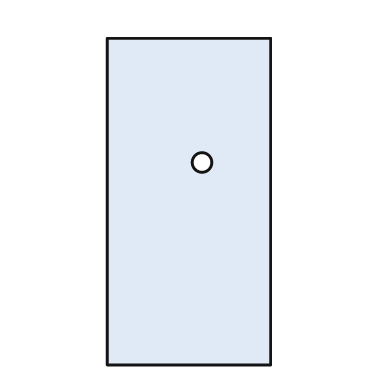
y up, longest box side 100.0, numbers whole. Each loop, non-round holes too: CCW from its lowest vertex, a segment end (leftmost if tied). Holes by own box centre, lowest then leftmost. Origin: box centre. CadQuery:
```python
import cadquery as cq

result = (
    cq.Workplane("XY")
    .moveTo(-25.0, -50.0)
    .lineTo(25.0, -50.0)
    .lineTo(25.0, 50.0)
    .lineTo(-25.0, 50.0)
    .close()
    .moveTo(4.0, 12.0)
    .circle(3.0)
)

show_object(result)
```